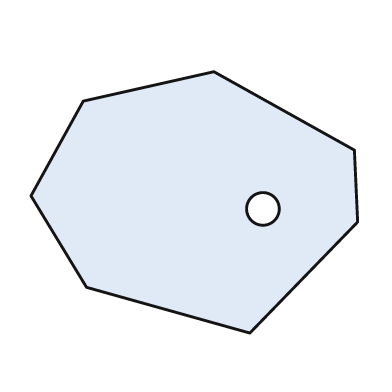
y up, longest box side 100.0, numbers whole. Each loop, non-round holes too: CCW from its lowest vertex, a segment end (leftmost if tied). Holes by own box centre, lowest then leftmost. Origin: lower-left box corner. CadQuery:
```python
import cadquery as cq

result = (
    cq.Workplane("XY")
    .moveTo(67.0, 0.0)
    .lineTo(100.0, 34.0)
    .lineTo(99.0, 56.0)
    .lineTo(56.0, 80.0)
    .lineTo(16.0, 71.0)
    .lineTo(0.0, 42.0)
    .lineTo(17.0, 14.0)
    .close()
    .moveTo(71.0, 38.0)
    .circle(5.0)
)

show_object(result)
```